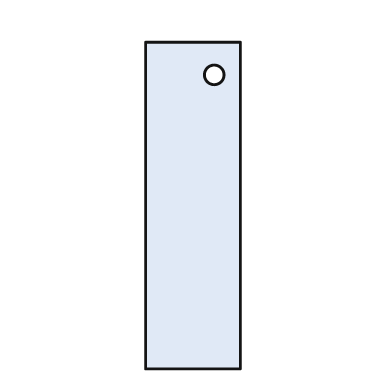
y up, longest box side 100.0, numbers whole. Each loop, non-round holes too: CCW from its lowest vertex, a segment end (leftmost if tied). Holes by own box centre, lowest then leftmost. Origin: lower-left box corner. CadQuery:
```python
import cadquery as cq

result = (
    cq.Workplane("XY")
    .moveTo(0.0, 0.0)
    .lineTo(29.0, 0.0)
    .lineTo(29.0, 100.0)
    .lineTo(0.0, 100.0)
    .close()
    .moveTo(21.0, 90.0)
    .circle(3.0)
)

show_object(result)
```